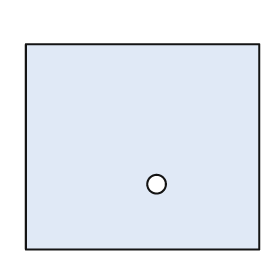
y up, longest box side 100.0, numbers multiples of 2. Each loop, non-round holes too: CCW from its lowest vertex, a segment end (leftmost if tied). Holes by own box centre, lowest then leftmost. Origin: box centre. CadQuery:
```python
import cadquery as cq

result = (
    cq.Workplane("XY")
    .moveTo(-50.0, -44.0)
    .lineTo(50.0, -44.0)
    .lineTo(50.0, 44.0)
    .lineTo(-50.0, 44.0)
    .close()
    .moveTo(6.0, -16.0)
    .circle(4.0)
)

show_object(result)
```